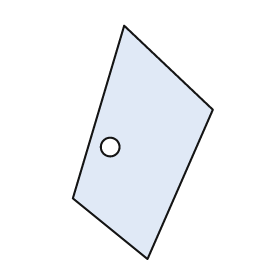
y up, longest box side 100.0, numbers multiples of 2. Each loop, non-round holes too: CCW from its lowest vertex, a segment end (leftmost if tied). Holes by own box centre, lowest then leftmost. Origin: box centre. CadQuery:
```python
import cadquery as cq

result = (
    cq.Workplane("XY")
    .moveTo(2.0, -50.0)
    .lineTo(30.0, 14.0)
    .lineTo(-8.0, 50.0)
    .lineTo(-30.0, -24.0)
    .close()
    .moveTo(-14.0, -2.0)
    .circle(4.0)
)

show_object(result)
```